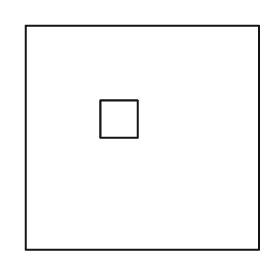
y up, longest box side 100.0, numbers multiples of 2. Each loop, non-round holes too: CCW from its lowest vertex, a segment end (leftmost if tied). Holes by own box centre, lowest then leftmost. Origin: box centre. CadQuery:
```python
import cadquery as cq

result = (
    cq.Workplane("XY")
    .moveTo(-50.0, -48.0)
    .lineTo(50.0, -48.0)
    .lineTo(50.0, 48.0)
    .lineTo(-50.0, 48.0)
    .close()
    .moveTo(-18.0, 0.0)
    .lineTo(-2.0, 0.0)
    .lineTo(-2.0, 16.0)
    .lineTo(-18.0, 16.0)
    .close()
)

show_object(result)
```